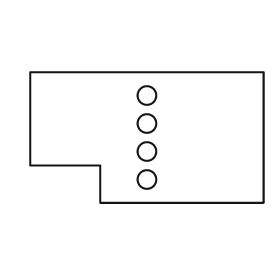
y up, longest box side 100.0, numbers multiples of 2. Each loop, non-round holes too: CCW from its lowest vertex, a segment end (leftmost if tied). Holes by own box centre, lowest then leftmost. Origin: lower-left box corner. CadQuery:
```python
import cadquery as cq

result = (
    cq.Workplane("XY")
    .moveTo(30.0, 0.0)
    .lineTo(100.0, 0.0)
    .lineTo(100.0, 56.0)
    .lineTo(0.0, 56.0)
    .lineTo(0.0, 16.0)
    .lineTo(30.0, 16.0)
    .close()
    .moveTo(50.0, 10.0)
    .circle(4.0)
    .moveTo(50.0, 22.0)
    .circle(4.0)
    .moveTo(50.0, 34.0)
    .circle(4.0)
    .moveTo(50.0, 46.0)
    .circle(4.0)
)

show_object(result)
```